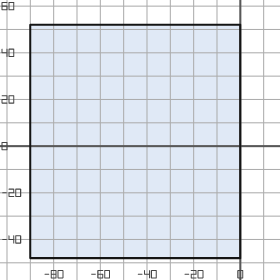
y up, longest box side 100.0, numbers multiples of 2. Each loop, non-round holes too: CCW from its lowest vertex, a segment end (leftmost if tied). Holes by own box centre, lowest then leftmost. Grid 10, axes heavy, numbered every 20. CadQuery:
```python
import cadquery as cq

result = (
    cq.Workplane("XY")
    .moveTo(-90.0, -48.0)
    .lineTo(0.0, -48.0)
    .lineTo(0.0, 52.0)
    .lineTo(-90.0, 52.0)
    .close()
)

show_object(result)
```